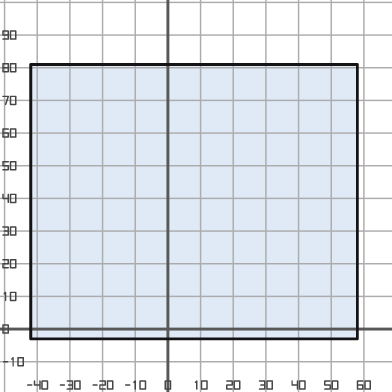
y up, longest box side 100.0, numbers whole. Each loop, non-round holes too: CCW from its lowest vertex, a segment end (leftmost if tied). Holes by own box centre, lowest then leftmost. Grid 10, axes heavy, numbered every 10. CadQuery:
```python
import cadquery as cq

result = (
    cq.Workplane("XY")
    .moveTo(-42.0, -3.0)
    .lineTo(58.0, -3.0)
    .lineTo(58.0, 81.0)
    .lineTo(-42.0, 81.0)
    .close()
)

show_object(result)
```